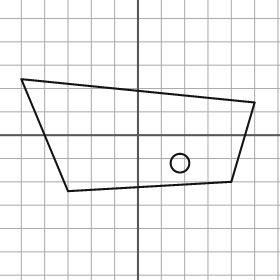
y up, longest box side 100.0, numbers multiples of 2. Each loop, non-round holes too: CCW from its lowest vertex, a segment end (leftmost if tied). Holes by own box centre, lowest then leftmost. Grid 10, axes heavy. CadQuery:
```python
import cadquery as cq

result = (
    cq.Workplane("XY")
    .moveTo(-30.0, -24.0)
    .lineTo(40.0, -20.0)
    .lineTo(50.0, 14.0)
    .lineTo(-50.0, 24.0)
    .close()
    .moveTo(18.0, -12.0)
    .circle(4.0)
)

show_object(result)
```